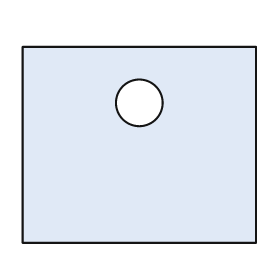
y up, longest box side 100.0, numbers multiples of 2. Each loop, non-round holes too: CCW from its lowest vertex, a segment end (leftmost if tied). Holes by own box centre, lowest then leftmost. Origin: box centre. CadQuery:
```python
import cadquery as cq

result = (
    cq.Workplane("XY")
    .moveTo(-50.0, -42.0)
    .lineTo(50.0, -42.0)
    .lineTo(50.0, 42.0)
    .lineTo(-50.0, 42.0)
    .close()
    .moveTo(0.0, 18.0)
    .circle(10.0)
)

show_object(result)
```